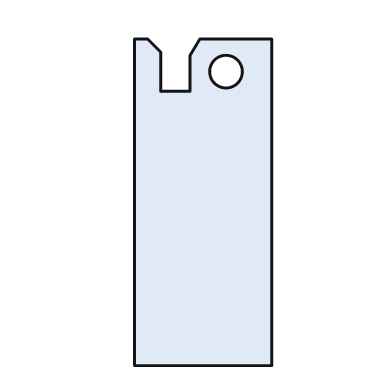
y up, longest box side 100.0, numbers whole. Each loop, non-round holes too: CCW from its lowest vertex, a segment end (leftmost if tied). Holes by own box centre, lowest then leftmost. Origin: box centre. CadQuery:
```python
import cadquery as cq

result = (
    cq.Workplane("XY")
    .moveTo(-21.0, -50.0)
    .lineTo(21.0, -50.0)
    .lineTo(21.0, 50.0)
    .lineTo(-1.0, 50.0)
    .lineTo(-4.0, 45.0)
    .lineTo(-4.0, 34.0)
    .lineTo(-13.0, 34.0)
    .lineTo(-13.0, 46.0)
    .lineTo(-17.0, 50.0)
    .lineTo(-21.0, 50.0)
    .close()
    .moveTo(7.0, 40.0)
    .circle(5.0)
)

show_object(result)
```